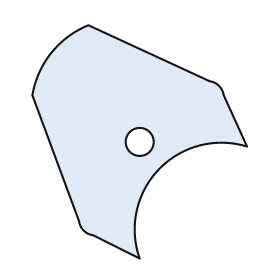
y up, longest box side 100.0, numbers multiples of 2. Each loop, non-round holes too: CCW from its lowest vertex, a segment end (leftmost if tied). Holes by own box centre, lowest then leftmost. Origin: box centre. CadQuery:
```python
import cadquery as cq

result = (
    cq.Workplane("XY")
    .moveTo(0.0, -50.0)
    .threePointArc((8.0, -12.0), (46.0, -2.0))
    .lineTo(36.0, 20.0)
    .threePointArc((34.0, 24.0), (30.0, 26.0))
    .lineTo(-22.0, 50.0)
    .threePointArc((-38.0, 38.0), (-46.0, 20.0))
    .lineTo(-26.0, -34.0)
    .threePointArc((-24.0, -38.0), (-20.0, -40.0))
    .close()
    .moveTo(0.0, 0.0)
    .circle(6.0)
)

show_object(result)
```